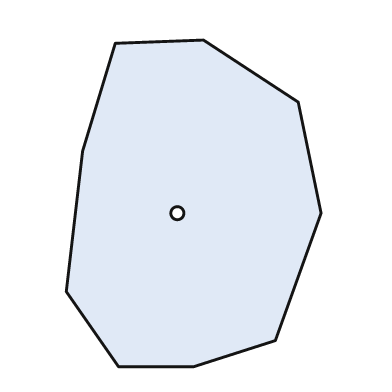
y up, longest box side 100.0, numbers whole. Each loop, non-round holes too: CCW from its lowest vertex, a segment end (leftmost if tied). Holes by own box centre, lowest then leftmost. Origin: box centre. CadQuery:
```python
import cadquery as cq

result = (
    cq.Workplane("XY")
    .moveTo(-23.0, -50.0)
    .lineTo(0.0, -50.0)
    .lineTo(25.0, -42.0)
    .lineTo(39.0, -3.0)
    .lineTo(32.0, 31.0)
    .lineTo(3.0, 50.0)
    .lineTo(-24.0, 49.0)
    .lineTo(-34.0, 16.0)
    .lineTo(-39.0, -27.0)
    .close()
    .moveTo(-5.0, -3.0)
    .circle(2.0)
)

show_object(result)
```